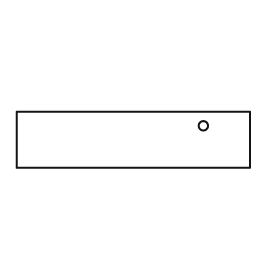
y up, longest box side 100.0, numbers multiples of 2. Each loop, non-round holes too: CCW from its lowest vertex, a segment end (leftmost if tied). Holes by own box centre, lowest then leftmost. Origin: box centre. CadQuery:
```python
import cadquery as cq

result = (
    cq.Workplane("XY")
    .moveTo(-50.0, -12.0)
    .lineTo(50.0, -12.0)
    .lineTo(50.0, 12.0)
    .lineTo(-50.0, 12.0)
    .close()
    .moveTo(30.0, 6.0)
    .circle(2.0)
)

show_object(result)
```